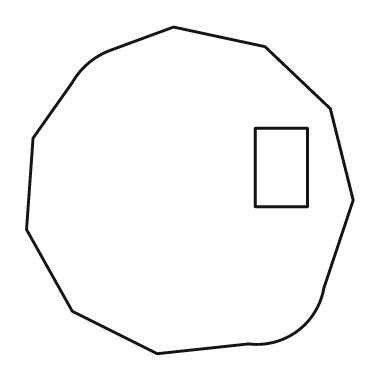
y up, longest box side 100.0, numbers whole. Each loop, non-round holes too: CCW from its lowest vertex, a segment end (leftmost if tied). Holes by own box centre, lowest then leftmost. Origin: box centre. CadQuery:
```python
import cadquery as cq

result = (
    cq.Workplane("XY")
    .moveTo(-10.0, -50.0)
    .lineTo(18.0, -47.0)
    .threePointArc((33.0, -43.0), (41.0, -30.0))
    .lineTo(50.0, -3.0)
    .lineTo(43.0, 25.0)
    .lineTo(23.0, 44.0)
    .lineTo(-5.0, 50.0)
    .lineTo(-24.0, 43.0)
    .threePointArc((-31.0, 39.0), (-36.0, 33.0))
    .lineTo(-48.0, 16.0)
    .lineTo(-50.0, -12.0)
    .lineTo(-36.0, -37.0)
    .close()
    .moveTo(20.0, -5.0)
    .lineTo(36.0, -5.0)
    .lineTo(36.0, 19.0)
    .lineTo(20.0, 19.0)
    .close()
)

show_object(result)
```